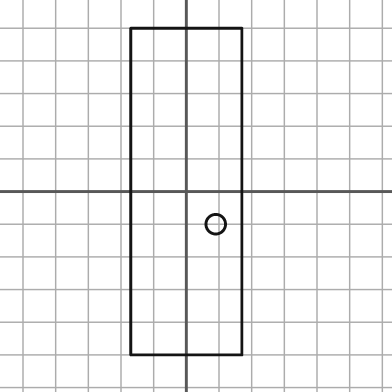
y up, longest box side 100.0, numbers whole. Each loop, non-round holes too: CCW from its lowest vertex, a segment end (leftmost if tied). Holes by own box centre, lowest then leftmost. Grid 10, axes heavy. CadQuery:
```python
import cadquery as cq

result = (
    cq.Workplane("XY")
    .moveTo(-17.0, -50.0)
    .lineTo(17.0, -50.0)
    .lineTo(17.0, 50.0)
    .lineTo(-17.0, 50.0)
    .close()
    .moveTo(9.0, -10.0)
    .circle(3.0)
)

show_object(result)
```